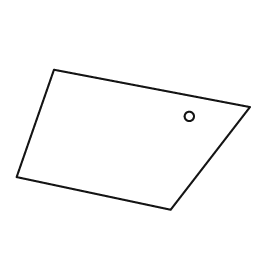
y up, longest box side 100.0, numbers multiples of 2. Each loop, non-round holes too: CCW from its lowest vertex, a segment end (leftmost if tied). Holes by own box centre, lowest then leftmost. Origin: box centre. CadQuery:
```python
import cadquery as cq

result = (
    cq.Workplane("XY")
    .moveTo(16.0, -30.0)
    .lineTo(50.0, 14.0)
    .lineTo(-34.0, 30.0)
    .lineTo(-50.0, -16.0)
    .close()
    .moveTo(24.0, 10.0)
    .circle(2.0)
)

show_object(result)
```